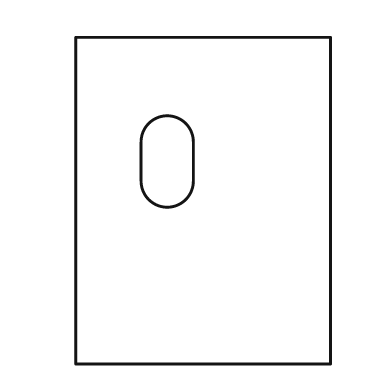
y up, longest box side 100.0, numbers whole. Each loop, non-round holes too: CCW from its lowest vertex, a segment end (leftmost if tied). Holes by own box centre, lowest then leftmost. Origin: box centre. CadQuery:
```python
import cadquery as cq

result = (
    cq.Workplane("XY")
    .moveTo(-39.0, -50.0)
    .lineTo(39.0, -50.0)
    .lineTo(39.0, 50.0)
    .lineTo(-39.0, 50.0)
    .close()
    .moveTo(-19.0, 6.0)
    .threePointArc((-11.0, -2.0), (-3.0, 6.0))
    .lineTo(-3.0, 18.0)
    .threePointArc((-11.0, 26.0), (-19.0, 18.0))
    .close()
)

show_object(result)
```